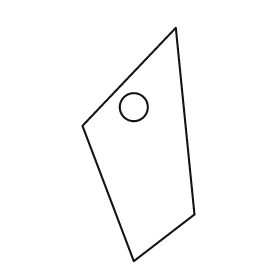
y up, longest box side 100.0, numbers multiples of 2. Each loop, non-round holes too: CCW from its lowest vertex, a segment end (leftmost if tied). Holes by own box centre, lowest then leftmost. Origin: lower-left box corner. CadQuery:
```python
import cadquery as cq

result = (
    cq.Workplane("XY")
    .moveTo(22.0, 0.0)
    .lineTo(48.0, 20.0)
    .lineTo(40.0, 100.0)
    .lineTo(0.0, 58.0)
    .close()
    .moveTo(22.0, 66.0)
    .circle(6.0)
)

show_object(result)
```